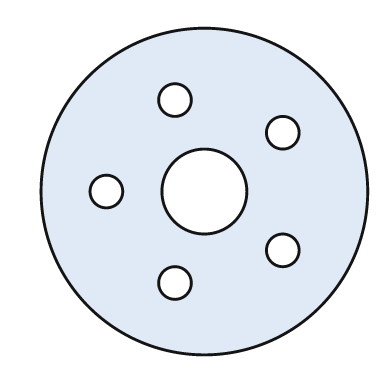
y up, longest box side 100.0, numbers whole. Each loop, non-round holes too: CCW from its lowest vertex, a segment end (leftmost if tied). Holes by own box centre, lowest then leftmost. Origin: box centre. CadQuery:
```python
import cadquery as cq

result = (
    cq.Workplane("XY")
    .moveTo(0.0, 0.0)
    .circle(50.0)
    .moveTo(-9.0, -28.0)
    .circle(5.0)
    .moveTo(24.0, -18.0)
    .circle(5.0)
    .moveTo(-30.0, 0.0)
    .circle(5.0)
    .moveTo(0.0, 0.0)
    .circle(13.0)
    .moveTo(24.0, 18.0)
    .circle(5.0)
    .moveTo(-9.0, 28.0)
    .circle(5.0)
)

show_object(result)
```